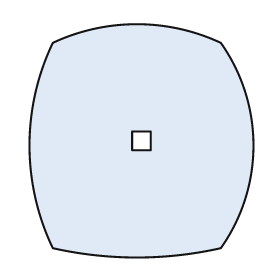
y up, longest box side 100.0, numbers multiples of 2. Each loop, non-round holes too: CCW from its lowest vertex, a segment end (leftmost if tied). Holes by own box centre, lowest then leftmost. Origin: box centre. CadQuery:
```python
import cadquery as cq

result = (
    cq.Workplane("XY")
    .moveTo(-38.0, -46.0)
    .threePointArc((-2.0, -50.0), (34.0, -46.0))
    .threePointArc((48.0, -2.0), (34.0, 42.0))
    .threePointArc((-2.0, 50.0), (-38.0, 42.0))
    .threePointArc((-48.0, -2.0), (-38.0, -46.0))
    .close()
    .moveTo(-4.0, -4.0)
    .lineTo(4.0, -4.0)
    .lineTo(4.0, 4.0)
    .lineTo(-4.0, 4.0)
    .close()
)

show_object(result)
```